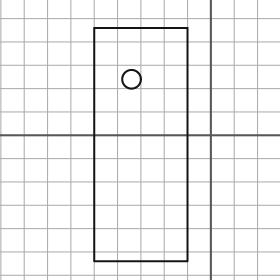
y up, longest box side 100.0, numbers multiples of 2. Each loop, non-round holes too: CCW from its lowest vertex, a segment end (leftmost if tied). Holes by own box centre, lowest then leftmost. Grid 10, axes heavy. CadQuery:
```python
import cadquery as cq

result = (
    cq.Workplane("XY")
    .moveTo(-50.0, -54.0)
    .lineTo(-10.0, -54.0)
    .lineTo(-10.0, 46.0)
    .lineTo(-50.0, 46.0)
    .close()
    .moveTo(-34.0, 24.0)
    .circle(4.0)
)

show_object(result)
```